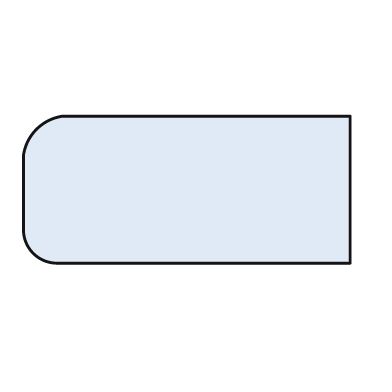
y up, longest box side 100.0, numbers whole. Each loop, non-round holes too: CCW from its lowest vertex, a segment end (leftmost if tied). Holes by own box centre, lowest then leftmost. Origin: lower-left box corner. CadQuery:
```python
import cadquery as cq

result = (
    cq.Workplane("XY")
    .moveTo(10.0, 0.0)
    .lineTo(100.0, 0.0)
    .lineTo(100.0, 45.0)
    .lineTo(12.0, 45.0)
    .threePointArc((4.0, 41.0), (0.0, 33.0))
    .lineTo(0.0, 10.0)
    .threePointArc((3.0, 3.0), (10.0, 0.0))
    .close()
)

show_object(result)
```